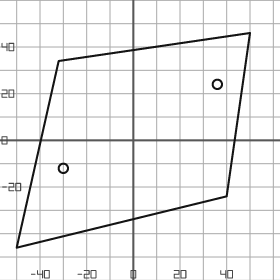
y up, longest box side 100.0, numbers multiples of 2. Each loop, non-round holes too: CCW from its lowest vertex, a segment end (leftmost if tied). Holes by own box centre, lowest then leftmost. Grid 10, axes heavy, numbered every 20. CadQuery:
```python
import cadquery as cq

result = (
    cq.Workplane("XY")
    .moveTo(-50.0, -46.0)
    .lineTo(40.0, -24.0)
    .lineTo(50.0, 46.0)
    .lineTo(-32.0, 34.0)
    .close()
    .moveTo(-30.0, -12.0)
    .circle(2.0)
    .moveTo(36.0, 24.0)
    .circle(2.0)
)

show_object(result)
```